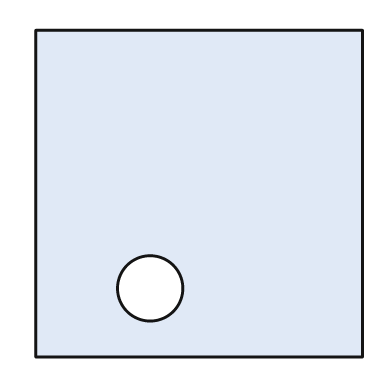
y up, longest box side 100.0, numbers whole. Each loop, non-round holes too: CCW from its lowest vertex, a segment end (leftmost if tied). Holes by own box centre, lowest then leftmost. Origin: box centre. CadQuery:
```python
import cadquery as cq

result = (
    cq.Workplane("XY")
    .moveTo(-50.0, -50.0)
    .lineTo(50.0, -50.0)
    .lineTo(50.0, 50.0)
    .lineTo(-50.0, 50.0)
    .close()
    .moveTo(-15.0, -29.0)
    .circle(10.0)
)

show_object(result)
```